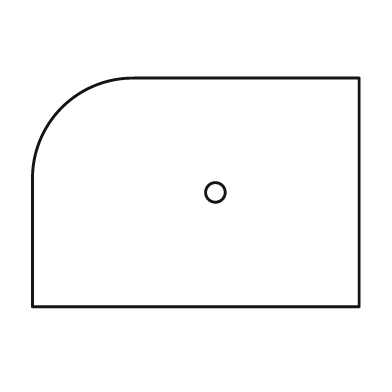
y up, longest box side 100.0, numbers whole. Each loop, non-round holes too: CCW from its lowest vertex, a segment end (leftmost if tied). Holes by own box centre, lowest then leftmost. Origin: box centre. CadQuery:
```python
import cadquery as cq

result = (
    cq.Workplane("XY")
    .moveTo(-50.0, -35.0)
    .lineTo(50.0, -35.0)
    .lineTo(50.0, 35.0)
    .lineTo(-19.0, 35.0)
    .threePointArc((-41.0, 26.0), (-50.0, 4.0))
    .close()
    .moveTo(6.0, 0.0)
    .circle(3.0)
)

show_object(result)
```